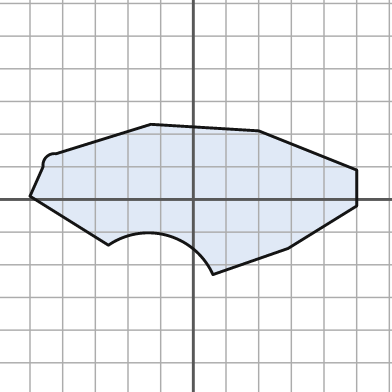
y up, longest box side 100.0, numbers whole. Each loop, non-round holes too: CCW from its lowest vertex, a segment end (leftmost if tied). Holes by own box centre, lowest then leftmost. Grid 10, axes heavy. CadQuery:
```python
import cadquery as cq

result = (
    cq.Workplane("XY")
    .moveTo(6.0, -23.0)
    .lineTo(29.0, -15.0)
    .lineTo(50.0, -2.0)
    .lineTo(50.0, 9.0)
    .lineTo(20.0, 21.0)
    .lineTo(-13.0, 23.0)
    .lineTo(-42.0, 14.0)
    .threePointArc((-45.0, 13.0), (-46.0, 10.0))
    .lineTo(-50.0, 1.0)
    .lineTo(-26.0, -14.0)
    .threePointArc((-8.0, -11.0), (6.0, -23.0))
    .close()
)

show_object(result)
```